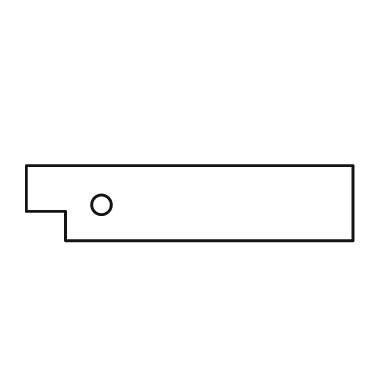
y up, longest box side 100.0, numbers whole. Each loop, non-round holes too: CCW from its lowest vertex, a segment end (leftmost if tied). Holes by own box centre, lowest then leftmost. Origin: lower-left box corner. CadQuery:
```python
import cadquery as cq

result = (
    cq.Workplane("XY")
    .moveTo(12.0, 0.0)
    .lineTo(100.0, 0.0)
    .lineTo(100.0, 23.0)
    .lineTo(0.0, 23.0)
    .lineTo(0.0, 9.0)
    .lineTo(12.0, 9.0)
    .close()
    .moveTo(23.0, 11.0)
    .circle(3.0)
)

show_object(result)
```